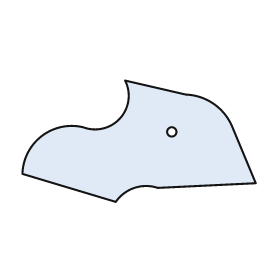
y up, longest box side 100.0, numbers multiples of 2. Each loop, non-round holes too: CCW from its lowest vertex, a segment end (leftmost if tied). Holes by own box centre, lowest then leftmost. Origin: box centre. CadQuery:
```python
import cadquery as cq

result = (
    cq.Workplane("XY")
    .moveTo(-10.0, -26.0)
    .threePointArc((-2.0, -20.0), (8.0, -20.0))
    .lineTo(50.0, -18.0)
    .lineTo(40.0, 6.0)
    .threePointArc((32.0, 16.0), (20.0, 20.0))
    .lineTo(-6.0, 26.0)
    .threePointArc((-8.0, 10.0), (-24.0, 6.0))
    .threePointArc((-42.0, 2.0), (-50.0, -14.0))
    .close()
    .moveTo(14.0, 4.0)
    .circle(2.0)
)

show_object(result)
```